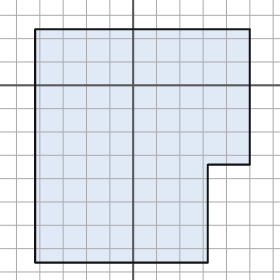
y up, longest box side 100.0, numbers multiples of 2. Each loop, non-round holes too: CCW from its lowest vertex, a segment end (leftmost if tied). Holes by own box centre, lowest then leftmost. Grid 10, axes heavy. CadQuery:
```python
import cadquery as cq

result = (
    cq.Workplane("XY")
    .moveTo(-42.0, -76.0)
    .lineTo(32.0, -76.0)
    .lineTo(32.0, -34.0)
    .lineTo(50.0, -34.0)
    .lineTo(50.0, 24.0)
    .lineTo(-42.0, 24.0)
    .close()
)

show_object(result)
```